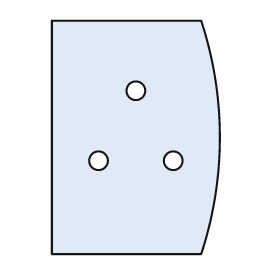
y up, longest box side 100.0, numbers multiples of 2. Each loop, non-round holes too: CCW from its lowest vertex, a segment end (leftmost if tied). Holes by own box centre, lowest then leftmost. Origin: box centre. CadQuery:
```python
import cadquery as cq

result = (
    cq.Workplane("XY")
    .moveTo(-36.0, -50.0)
    .lineTo(28.0, -50.0)
    .threePointArc((36.0, 0.0), (28.0, 50.0))
    .lineTo(-36.0, 50.0)
    .close()
    .moveTo(-16.0, -10.0)
    .circle(4.0)
    .moveTo(16.0, -10.0)
    .circle(4.0)
    .moveTo(0.0, 20.0)
    .circle(4.0)
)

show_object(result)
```